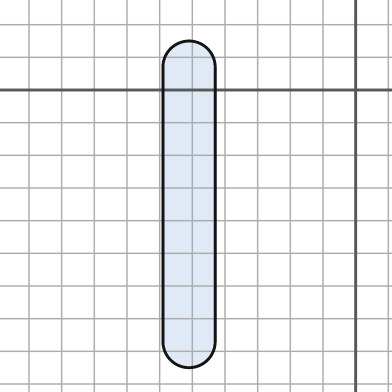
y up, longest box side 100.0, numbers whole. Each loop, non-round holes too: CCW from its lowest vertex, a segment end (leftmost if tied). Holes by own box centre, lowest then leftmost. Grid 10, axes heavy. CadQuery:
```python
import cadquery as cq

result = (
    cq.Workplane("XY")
    .moveTo(-59.0, -77.0)
    .threePointArc((-51.0, -85.0), (-43.0, -77.0))
    .lineTo(-43.0, 7.0)
    .threePointArc((-51.0, 15.0), (-59.0, 7.0))
    .close()
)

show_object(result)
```